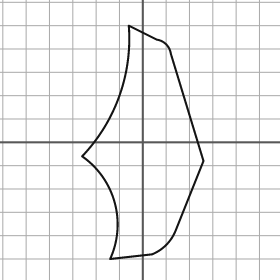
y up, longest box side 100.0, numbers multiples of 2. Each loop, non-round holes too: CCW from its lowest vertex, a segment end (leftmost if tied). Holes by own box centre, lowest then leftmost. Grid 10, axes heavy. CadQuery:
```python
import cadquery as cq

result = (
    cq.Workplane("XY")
    .moveTo(-14.0, -50.0)
    .lineTo(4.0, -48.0)
    .threePointArc((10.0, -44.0), (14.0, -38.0))
    .lineTo(26.0, -8.0)
    .lineTo(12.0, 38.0)
    .threePointArc((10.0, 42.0), (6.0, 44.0))
    .lineTo(-6.0, 50.0)
    .threePointArc((-10.0, 20.0), (-26.0, -6.0))
    .threePointArc((-12.0, -26.0), (-14.0, -50.0))
    .close()
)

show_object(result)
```